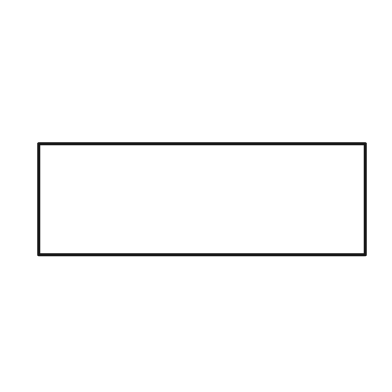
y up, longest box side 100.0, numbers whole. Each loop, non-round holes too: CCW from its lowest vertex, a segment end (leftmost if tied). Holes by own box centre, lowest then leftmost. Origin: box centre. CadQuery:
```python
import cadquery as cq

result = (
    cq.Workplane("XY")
    .moveTo(-50.0, -17.0)
    .lineTo(50.0, -17.0)
    .lineTo(50.0, 17.0)
    .lineTo(-50.0, 17.0)
    .close()
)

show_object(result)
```